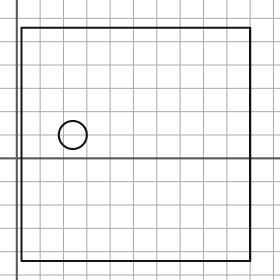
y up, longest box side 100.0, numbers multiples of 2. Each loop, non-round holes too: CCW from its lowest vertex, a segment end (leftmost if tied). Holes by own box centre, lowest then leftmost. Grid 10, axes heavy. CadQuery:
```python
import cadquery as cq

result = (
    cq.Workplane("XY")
    .moveTo(2.0, -44.0)
    .lineTo(100.0, -44.0)
    .lineTo(100.0, 56.0)
    .lineTo(2.0, 56.0)
    .close()
    .moveTo(24.0, 10.0)
    .circle(6.0)
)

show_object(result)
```